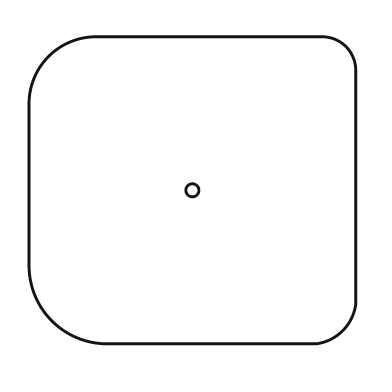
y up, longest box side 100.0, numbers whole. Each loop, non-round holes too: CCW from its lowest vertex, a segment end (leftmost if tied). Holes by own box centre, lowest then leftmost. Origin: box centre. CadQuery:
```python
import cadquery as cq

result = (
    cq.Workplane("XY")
    .moveTo(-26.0, -47.0)
    .lineTo(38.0, -47.0)
    .threePointArc((46.0, -43.0), (50.0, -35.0))
    .lineTo(50.0, 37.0)
    .threePointArc((47.0, 44.0), (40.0, 47.0))
    .lineTo(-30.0, 47.0)
    .threePointArc((-44.0, 41.0), (-50.0, 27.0))
    .lineTo(-50.0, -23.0)
    .threePointArc((-43.0, -40.0), (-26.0, -47.0))
    .close()
    .moveTo(0.0, 0.0)
    .circle(2.0)
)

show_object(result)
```